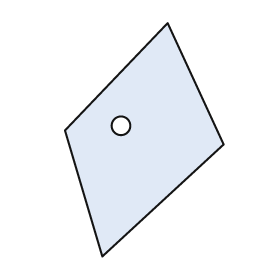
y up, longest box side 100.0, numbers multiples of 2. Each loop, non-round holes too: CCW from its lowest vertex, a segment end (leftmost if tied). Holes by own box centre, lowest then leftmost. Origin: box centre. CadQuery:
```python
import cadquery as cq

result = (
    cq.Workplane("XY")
    .moveTo(-18.0, -50.0)
    .lineTo(34.0, -2.0)
    .lineTo(10.0, 50.0)
    .lineTo(-34.0, 4.0)
    .close()
    .moveTo(-10.0, 6.0)
    .circle(4.0)
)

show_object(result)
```